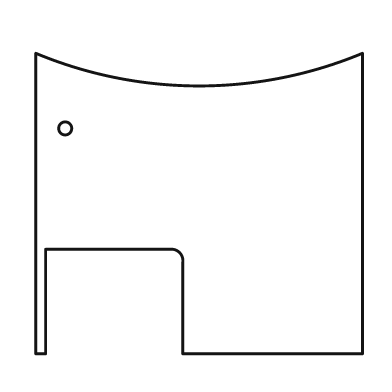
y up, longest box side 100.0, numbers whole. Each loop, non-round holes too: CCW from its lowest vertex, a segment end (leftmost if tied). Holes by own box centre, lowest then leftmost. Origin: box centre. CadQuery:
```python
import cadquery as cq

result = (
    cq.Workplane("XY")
    .moveTo(-50.0, -46.0)
    .lineTo(-47.0, -46.0)
    .lineTo(-47.0, -14.0)
    .lineTo(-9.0, -14.0)
    .threePointArc((-6.0, -15.0), (-5.0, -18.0))
    .lineTo(-5.0, -46.0)
    .lineTo(50.0, -46.0)
    .lineTo(50.0, 46.0)
    .threePointArc((0.0, 36.0), (-50.0, 46.0))
    .close()
    .moveTo(-41.0, 23.0)
    .circle(2.0)
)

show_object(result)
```